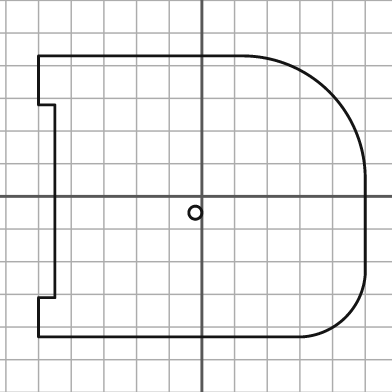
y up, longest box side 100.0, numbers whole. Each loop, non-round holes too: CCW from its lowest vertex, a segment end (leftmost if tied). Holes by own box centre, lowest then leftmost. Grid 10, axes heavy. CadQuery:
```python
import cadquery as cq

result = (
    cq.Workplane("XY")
    .moveTo(-50.0, -43.0)
    .lineTo(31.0, -43.0)
    .threePointArc((44.0, -37.0), (50.0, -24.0))
    .lineTo(50.0, 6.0)
    .threePointArc((39.0, 32.0), (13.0, 43.0))
    .lineTo(-50.0, 43.0)
    .lineTo(-50.0, 28.0)
    .lineTo(-45.0, 28.0)
    .lineTo(-45.0, -31.0)
    .lineTo(-50.0, -31.0)
    .close()
    .moveTo(-2.0, -5.0)
    .circle(2.0)
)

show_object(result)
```